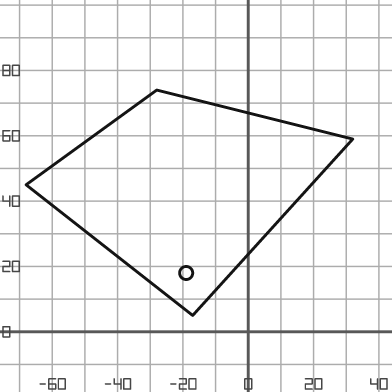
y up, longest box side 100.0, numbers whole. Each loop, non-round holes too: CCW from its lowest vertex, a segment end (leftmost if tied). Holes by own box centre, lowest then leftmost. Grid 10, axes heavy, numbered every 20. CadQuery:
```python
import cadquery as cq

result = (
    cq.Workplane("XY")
    .moveTo(-17.0, 5.0)
    .lineTo(32.0, 59.0)
    .lineTo(-28.0, 74.0)
    .lineTo(-68.0, 45.0)
    .close()
    .moveTo(-19.0, 18.0)
    .circle(2.0)
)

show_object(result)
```